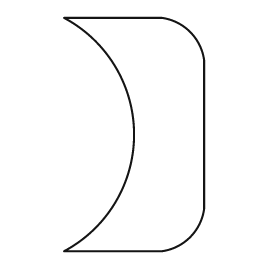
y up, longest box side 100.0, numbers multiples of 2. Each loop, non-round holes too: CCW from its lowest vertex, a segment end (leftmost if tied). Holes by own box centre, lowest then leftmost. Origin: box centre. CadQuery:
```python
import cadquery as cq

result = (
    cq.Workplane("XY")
    .moveTo(-30.0, -50.0)
    .lineTo(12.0, -50.0)
    .threePointArc((24.0, -44.0), (30.0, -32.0))
    .lineTo(30.0, 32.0)
    .threePointArc((24.0, 44.0), (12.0, 50.0))
    .lineTo(-30.0, 50.0)
    .threePointArc((0.0, 0.0), (-30.0, -50.0))
    .close()
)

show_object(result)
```